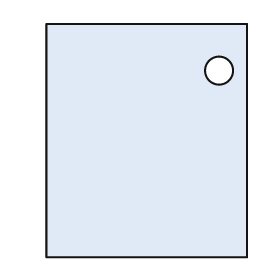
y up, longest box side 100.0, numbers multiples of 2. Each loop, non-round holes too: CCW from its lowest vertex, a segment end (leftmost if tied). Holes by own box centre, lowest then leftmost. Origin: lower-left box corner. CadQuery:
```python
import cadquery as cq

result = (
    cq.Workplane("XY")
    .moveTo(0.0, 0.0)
    .lineTo(86.0, 0.0)
    .lineTo(86.0, 100.0)
    .lineTo(0.0, 100.0)
    .close()
    .moveTo(74.0, 80.0)
    .circle(6.0)
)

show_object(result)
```